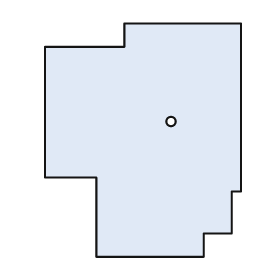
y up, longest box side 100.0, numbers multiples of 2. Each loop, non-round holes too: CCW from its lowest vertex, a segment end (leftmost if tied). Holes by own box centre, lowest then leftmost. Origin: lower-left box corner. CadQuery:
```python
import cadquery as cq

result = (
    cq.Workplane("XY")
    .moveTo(22.0, 0.0)
    .lineTo(68.0, 0.0)
    .lineTo(68.0, 10.0)
    .lineTo(80.0, 10.0)
    .lineTo(80.0, 28.0)
    .lineTo(84.0, 28.0)
    .lineTo(84.0, 100.0)
    .lineTo(34.0, 100.0)
    .lineTo(34.0, 90.0)
    .lineTo(0.0, 90.0)
    .lineTo(0.0, 34.0)
    .lineTo(22.0, 34.0)
    .close()
    .moveTo(54.0, 58.0)
    .circle(2.0)
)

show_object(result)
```